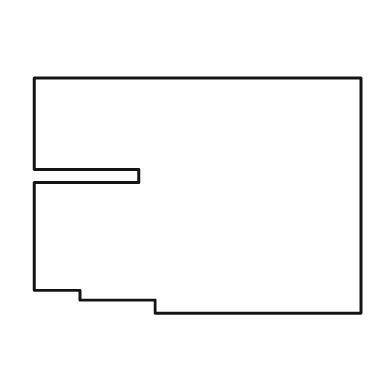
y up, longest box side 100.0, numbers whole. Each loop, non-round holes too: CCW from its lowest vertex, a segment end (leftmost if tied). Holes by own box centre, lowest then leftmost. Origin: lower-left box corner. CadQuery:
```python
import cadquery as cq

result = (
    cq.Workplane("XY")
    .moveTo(37.0, 0.0)
    .lineTo(100.0, 0.0)
    .lineTo(100.0, 72.0)
    .lineTo(0.0, 72.0)
    .lineTo(0.0, 44.0)
    .lineTo(32.0, 44.0)
    .lineTo(32.0, 40.0)
    .lineTo(0.0, 40.0)
    .lineTo(0.0, 7.0)
    .lineTo(14.0, 7.0)
    .lineTo(14.0, 4.0)
    .lineTo(37.0, 4.0)
    .close()
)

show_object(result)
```